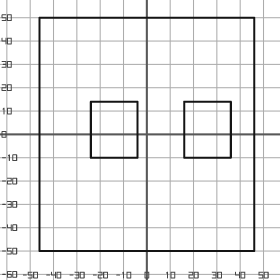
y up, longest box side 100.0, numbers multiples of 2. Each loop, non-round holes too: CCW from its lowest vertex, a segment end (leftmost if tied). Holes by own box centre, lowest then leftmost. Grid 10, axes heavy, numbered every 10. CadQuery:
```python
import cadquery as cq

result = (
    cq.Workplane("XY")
    .moveTo(-46.0, -50.0)
    .lineTo(46.0, -50.0)
    .lineTo(46.0, 50.0)
    .lineTo(-46.0, 50.0)
    .close()
    .moveTo(-24.0, -10.0)
    .lineTo(-4.0, -10.0)
    .lineTo(-4.0, 14.0)
    .lineTo(-24.0, 14.0)
    .close()
    .moveTo(16.0, -10.0)
    .lineTo(36.0, -10.0)
    .lineTo(36.0, 14.0)
    .lineTo(16.0, 14.0)
    .close()
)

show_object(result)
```